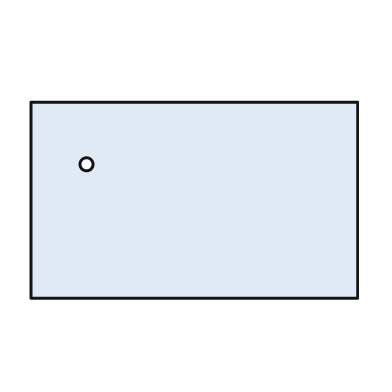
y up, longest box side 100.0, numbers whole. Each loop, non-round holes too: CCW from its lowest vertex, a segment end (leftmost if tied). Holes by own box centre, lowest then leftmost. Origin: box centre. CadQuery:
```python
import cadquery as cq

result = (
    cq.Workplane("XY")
    .moveTo(-50.0, -30.0)
    .lineTo(50.0, -30.0)
    .lineTo(50.0, 30.0)
    .lineTo(-50.0, 30.0)
    .close()
    .moveTo(-33.0, 11.0)
    .circle(2.0)
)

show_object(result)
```